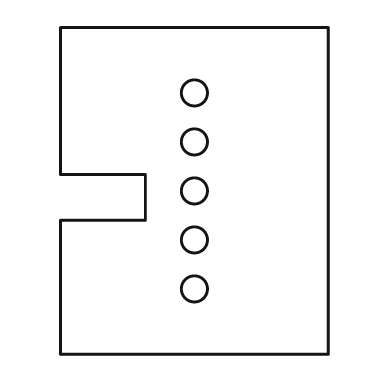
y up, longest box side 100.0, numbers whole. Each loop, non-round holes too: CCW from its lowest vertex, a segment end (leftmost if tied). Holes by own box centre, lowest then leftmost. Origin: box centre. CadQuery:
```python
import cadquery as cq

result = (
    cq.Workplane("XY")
    .moveTo(-41.0, -50.0)
    .lineTo(41.0, -50.0)
    .lineTo(41.0, 50.0)
    .lineTo(-41.0, 50.0)
    .lineTo(-41.0, 5.0)
    .lineTo(-15.0, 5.0)
    .lineTo(-15.0, -9.0)
    .lineTo(-41.0, -9.0)
    .close()
    .moveTo(0.0, -30.0)
    .circle(4.0)
    .moveTo(0.0, -15.0)
    .circle(4.0)
    .moveTo(0.0, 0.0)
    .circle(4.0)
    .moveTo(0.0, 15.0)
    .circle(4.0)
    .moveTo(0.0, 30.0)
    .circle(4.0)
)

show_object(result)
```